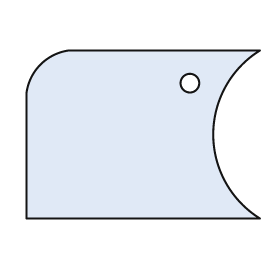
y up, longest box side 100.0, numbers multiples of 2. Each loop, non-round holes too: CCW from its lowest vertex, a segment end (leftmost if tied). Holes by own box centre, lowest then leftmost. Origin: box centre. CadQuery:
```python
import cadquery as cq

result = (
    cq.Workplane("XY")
    .moveTo(-50.0, -36.0)
    .lineTo(50.0, -36.0)
    .threePointArc((30.0, 0.0), (50.0, 36.0))
    .lineTo(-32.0, 36.0)
    .threePointArc((-44.0, 30.0), (-50.0, 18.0))
    .close()
    .moveTo(20.0, 22.0)
    .circle(4.0)
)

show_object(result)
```